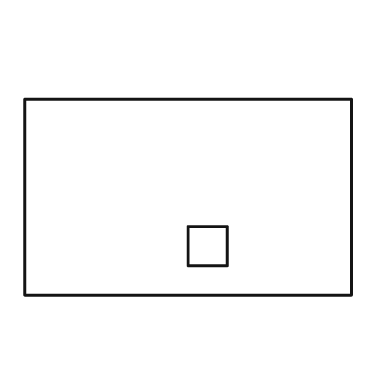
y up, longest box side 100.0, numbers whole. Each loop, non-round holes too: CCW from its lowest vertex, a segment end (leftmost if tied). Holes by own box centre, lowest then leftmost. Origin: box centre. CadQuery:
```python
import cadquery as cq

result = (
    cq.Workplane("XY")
    .moveTo(-50.0, -30.0)
    .lineTo(50.0, -30.0)
    .lineTo(50.0, 30.0)
    .lineTo(-50.0, 30.0)
    .close()
    .moveTo(0.0, -21.0)
    .lineTo(12.0, -21.0)
    .lineTo(12.0, -9.0)
    .lineTo(0.0, -9.0)
    .close()
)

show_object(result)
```